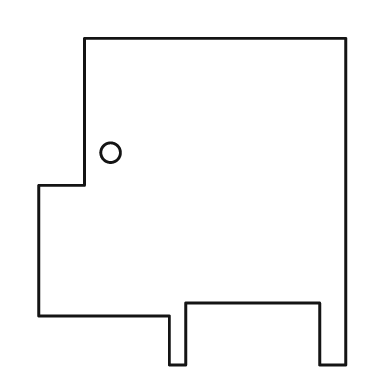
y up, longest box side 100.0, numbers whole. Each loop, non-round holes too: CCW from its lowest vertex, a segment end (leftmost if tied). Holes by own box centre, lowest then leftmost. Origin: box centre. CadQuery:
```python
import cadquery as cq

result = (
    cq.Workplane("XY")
    .moveTo(-7.0, -50.0)
    .lineTo(-2.0, -50.0)
    .lineTo(-2.0, -31.0)
    .lineTo(39.0, -31.0)
    .lineTo(39.0, -50.0)
    .lineTo(47.0, -50.0)
    .lineTo(47.0, 50.0)
    .lineTo(-33.0, 50.0)
    .lineTo(-33.0, 5.0)
    .lineTo(-47.0, 5.0)
    .lineTo(-47.0, -35.0)
    .lineTo(-7.0, -35.0)
    .close()
    .moveTo(-25.0, 15.0)
    .circle(3.0)
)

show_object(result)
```